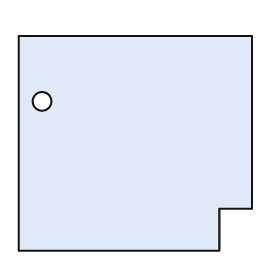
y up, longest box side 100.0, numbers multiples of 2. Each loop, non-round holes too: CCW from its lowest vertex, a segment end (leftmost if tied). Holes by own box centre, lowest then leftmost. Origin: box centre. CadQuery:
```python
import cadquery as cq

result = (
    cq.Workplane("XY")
    .moveTo(-50.0, -46.0)
    .lineTo(36.0, -46.0)
    .lineTo(36.0, -28.0)
    .lineTo(50.0, -28.0)
    .lineTo(50.0, 46.0)
    .lineTo(-50.0, 46.0)
    .close()
    .moveTo(-40.0, 18.0)
    .circle(4.0)
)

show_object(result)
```